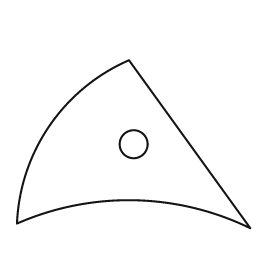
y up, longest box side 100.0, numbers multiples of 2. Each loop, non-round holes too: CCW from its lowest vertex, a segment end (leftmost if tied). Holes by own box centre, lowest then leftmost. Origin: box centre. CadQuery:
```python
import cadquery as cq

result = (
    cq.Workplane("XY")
    .moveTo(50.0, -36.0)
    .lineTo(-2.0, 36.0)
    .threePointArc((-36.0, 8.0), (-50.0, -34.0))
    .threePointArc((0.0, -24.0), (50.0, -36.0))
    .close()
    .moveTo(0.0, 0.0)
    .circle(6.0)
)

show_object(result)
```